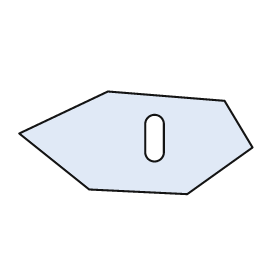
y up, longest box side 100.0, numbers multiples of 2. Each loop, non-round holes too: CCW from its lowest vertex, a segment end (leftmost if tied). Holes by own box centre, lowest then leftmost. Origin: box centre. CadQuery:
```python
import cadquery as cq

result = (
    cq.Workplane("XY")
    .moveTo(22.0, -22.0)
    .lineTo(50.0, -2.0)
    .lineTo(38.0, 18.0)
    .lineTo(-12.0, 22.0)
    .lineTo(-50.0, 4.0)
    .lineTo(-20.0, -20.0)
    .close()
    .moveTo(4.0, -4.0)
    .threePointArc((8.0, -8.0), (12.0, -4.0))
    .lineTo(12.0, 8.0)
    .threePointArc((8.0, 12.0), (4.0, 8.0))
    .close()
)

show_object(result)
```